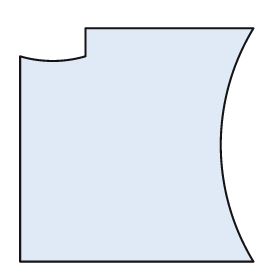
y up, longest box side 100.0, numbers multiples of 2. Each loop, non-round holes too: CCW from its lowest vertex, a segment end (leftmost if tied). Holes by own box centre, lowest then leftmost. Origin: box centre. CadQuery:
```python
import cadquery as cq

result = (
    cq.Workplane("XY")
    .moveTo(-50.0, -50.0)
    .lineTo(50.0, -50.0)
    .threePointArc((36.0, 0.0), (50.0, 50.0))
    .lineTo(-22.0, 50.0)
    .lineTo(-22.0, 38.0)
    .threePointArc((-36.0, 36.0), (-50.0, 38.0))
    .close()
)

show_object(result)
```